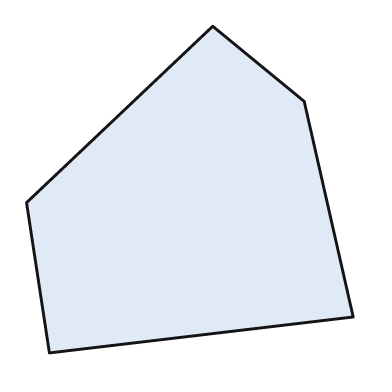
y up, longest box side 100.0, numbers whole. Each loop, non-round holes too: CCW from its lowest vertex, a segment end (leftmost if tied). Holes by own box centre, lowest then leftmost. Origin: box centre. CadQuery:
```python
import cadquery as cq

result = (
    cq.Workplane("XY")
    .moveTo(-43.0, -50.0)
    .lineTo(50.0, -39.0)
    .lineTo(35.0, 27.0)
    .lineTo(7.0, 50.0)
    .lineTo(-50.0, -4.0)
    .close()
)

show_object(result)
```